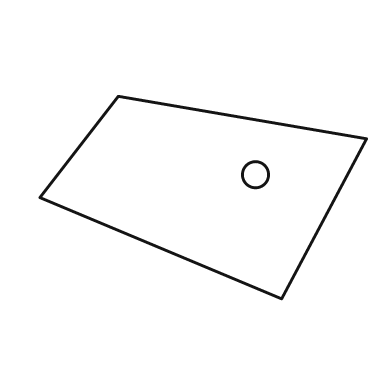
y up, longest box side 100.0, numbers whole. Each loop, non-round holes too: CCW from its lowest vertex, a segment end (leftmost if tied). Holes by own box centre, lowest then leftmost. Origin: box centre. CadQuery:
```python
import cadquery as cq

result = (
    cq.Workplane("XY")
    .moveTo(24.0, -31.0)
    .lineTo(50.0, 18.0)
    .lineTo(-26.0, 31.0)
    .lineTo(-50.0, 0.0)
    .close()
    .moveTo(16.0, 7.0)
    .circle(4.0)
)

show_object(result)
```